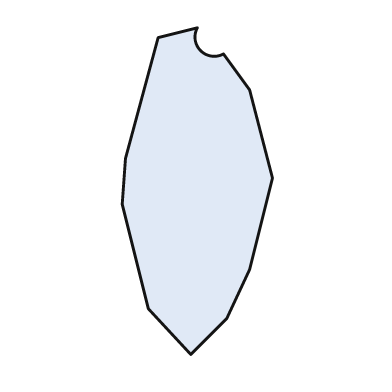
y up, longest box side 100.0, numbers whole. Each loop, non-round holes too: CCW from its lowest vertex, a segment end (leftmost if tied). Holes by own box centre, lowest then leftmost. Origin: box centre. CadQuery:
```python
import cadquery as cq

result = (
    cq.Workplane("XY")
    .moveTo(-2.0, -50.0)
    .lineTo(9.0, -39.0)
    .lineTo(16.0, -24.0)
    .lineTo(23.0, 4.0)
    .lineTo(16.0, 31.0)
    .lineTo(8.0, 42.0)
    .threePointArc((1.0, 43.0), (0.0, 50.0))
    .lineTo(-12.0, 47.0)
    .lineTo(-22.0, 10.0)
    .lineTo(-23.0, -4.0)
    .lineTo(-15.0, -36.0)
    .close()
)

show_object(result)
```